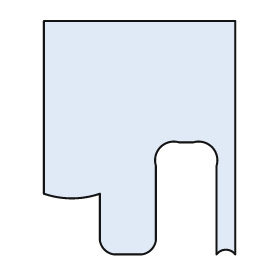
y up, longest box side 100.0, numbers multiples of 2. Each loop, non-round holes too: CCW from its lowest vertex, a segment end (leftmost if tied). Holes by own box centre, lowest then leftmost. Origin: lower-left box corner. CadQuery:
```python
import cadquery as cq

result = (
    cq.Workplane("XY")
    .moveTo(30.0, 0.0)
    .lineTo(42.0, 0.0)
    .threePointArc((46.0, 2.0), (48.0, 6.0))
    .lineTo(48.0, 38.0)
    .threePointArc((50.0, 46.0), (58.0, 48.0))
    .lineTo(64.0, 48.0)
    .threePointArc((72.0, 46.0), (74.0, 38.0))
    .lineTo(74.0, 0.0)
    .threePointArc((78.0, 2.0), (82.0, 0.0))
    .lineTo(82.0, 100.0)
    .lineTo(0.0, 100.0)
    .lineTo(0.0, 26.0)
    .threePointArc((12.0, 24.0), (24.0, 26.0))
    .lineTo(24.0, 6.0)
    .threePointArc((26.0, 2.0), (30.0, 0.0))
    .close()
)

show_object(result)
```